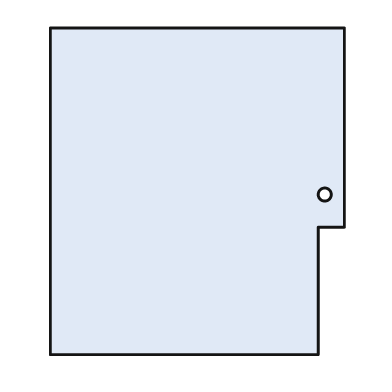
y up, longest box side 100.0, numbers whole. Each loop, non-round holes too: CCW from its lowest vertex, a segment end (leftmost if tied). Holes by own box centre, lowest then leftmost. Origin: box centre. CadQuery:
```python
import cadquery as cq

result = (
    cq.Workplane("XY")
    .moveTo(-45.0, -50.0)
    .lineTo(37.0, -50.0)
    .lineTo(37.0, -11.0)
    .lineTo(45.0, -11.0)
    .lineTo(45.0, 50.0)
    .lineTo(-45.0, 50.0)
    .close()
    .moveTo(39.0, -1.0)
    .circle(2.0)
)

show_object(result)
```